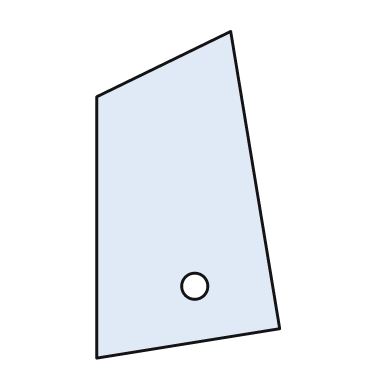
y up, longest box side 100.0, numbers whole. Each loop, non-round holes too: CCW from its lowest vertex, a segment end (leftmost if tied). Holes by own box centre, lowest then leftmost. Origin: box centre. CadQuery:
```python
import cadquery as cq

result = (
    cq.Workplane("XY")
    .moveTo(-28.0, -50.0)
    .lineTo(28.0, -41.0)
    .lineTo(13.0, 50.0)
    .lineTo(-28.0, 30.0)
    .close()
    .moveTo(2.0, -28.0)
    .circle(4.0)
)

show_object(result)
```